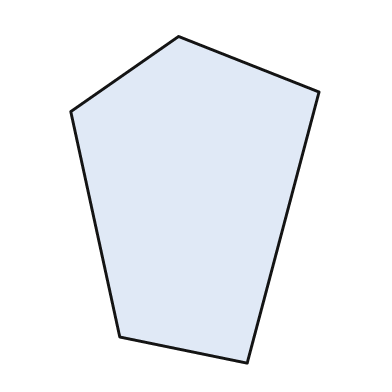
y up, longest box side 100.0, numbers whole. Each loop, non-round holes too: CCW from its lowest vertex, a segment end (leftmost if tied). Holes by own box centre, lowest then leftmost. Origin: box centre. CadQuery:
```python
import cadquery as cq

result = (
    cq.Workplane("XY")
    .moveTo(16.0, -50.0)
    .lineTo(38.0, 33.0)
    .lineTo(-5.0, 50.0)
    .lineTo(-38.0, 27.0)
    .lineTo(-23.0, -42.0)
    .close()
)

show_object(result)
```